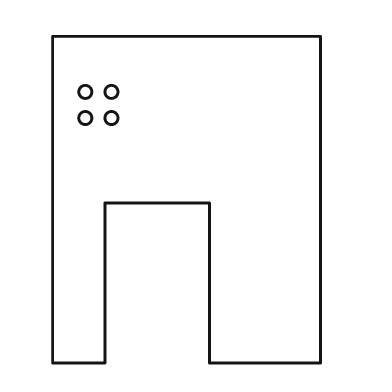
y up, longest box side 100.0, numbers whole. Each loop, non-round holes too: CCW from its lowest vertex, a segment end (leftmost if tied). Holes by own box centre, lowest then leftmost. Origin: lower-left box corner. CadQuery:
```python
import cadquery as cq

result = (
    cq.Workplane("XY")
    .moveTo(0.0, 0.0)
    .lineTo(16.0, 0.0)
    .lineTo(16.0, 49.0)
    .lineTo(48.0, 49.0)
    .lineTo(48.0, 0.0)
    .lineTo(82.0, 0.0)
    .lineTo(82.0, 100.0)
    .lineTo(0.0, 100.0)
    .close()
    .moveTo(10.0, 75.0)
    .circle(2.0)
    .moveTo(18.0, 75.0)
    .circle(2.0)
    .moveTo(10.0, 83.0)
    .circle(2.0)
    .moveTo(18.0, 83.0)
    .circle(2.0)
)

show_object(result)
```